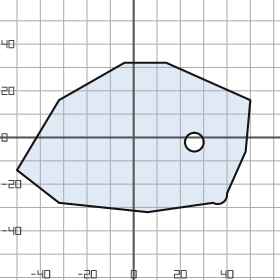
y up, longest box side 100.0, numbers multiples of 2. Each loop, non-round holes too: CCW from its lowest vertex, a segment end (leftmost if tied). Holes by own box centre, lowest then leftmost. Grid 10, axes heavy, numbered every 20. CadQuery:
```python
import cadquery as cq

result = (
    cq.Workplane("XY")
    .moveTo(6.0, -32.0)
    .lineTo(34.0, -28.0)
    .threePointArc((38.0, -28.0), (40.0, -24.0))
    .lineTo(48.0, -6.0)
    .lineTo(50.0, 16.0)
    .lineTo(14.0, 32.0)
    .lineTo(-4.0, 32.0)
    .lineTo(-32.0, 16.0)
    .lineTo(-50.0, -14.0)
    .lineTo(-32.0, -28.0)
    .close()
    .moveTo(26.0, -2.0)
    .circle(4.0)
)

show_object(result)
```